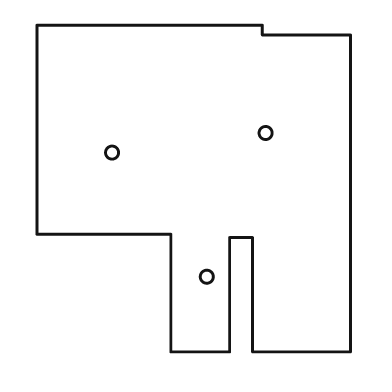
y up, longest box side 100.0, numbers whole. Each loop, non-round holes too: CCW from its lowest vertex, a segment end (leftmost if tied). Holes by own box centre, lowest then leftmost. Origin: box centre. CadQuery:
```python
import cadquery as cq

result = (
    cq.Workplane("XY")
    .moveTo(-7.0, -50.0)
    .lineTo(11.0, -50.0)
    .lineTo(11.0, -15.0)
    .lineTo(18.0, -15.0)
    .lineTo(18.0, -50.0)
    .lineTo(48.0, -50.0)
    .lineTo(48.0, 47.0)
    .lineTo(21.0, 47.0)
    .lineTo(21.0, 50.0)
    .lineTo(-48.0, 50.0)
    .lineTo(-48.0, -14.0)
    .lineTo(-7.0, -14.0)
    .close()
    .moveTo(4.0, -27.0)
    .circle(2.0)
    .moveTo(-25.0, 11.0)
    .circle(2.0)
    .moveTo(22.0, 17.0)
    .circle(2.0)
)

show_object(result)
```